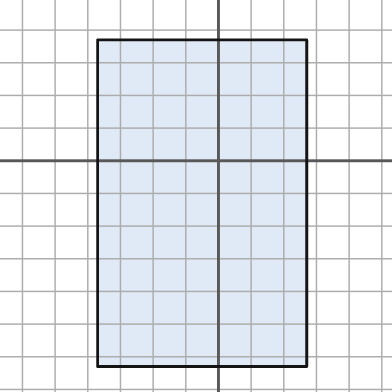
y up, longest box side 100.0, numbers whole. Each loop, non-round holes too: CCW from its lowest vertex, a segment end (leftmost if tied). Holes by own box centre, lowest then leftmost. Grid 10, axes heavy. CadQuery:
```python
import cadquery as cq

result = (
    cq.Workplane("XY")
    .moveTo(-37.0, -63.0)
    .lineTo(27.0, -63.0)
    .lineTo(27.0, 37.0)
    .lineTo(-37.0, 37.0)
    .close()
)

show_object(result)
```